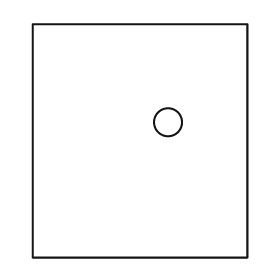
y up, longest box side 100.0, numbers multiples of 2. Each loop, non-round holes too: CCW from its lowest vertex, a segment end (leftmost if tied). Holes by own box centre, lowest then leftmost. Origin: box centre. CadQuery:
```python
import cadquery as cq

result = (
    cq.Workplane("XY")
    .moveTo(-46.0, -50.0)
    .lineTo(46.0, -50.0)
    .lineTo(46.0, 50.0)
    .lineTo(-46.0, 50.0)
    .close()
    .moveTo(12.0, 8.0)
    .circle(6.0)
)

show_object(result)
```